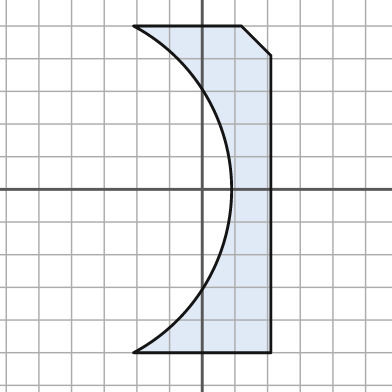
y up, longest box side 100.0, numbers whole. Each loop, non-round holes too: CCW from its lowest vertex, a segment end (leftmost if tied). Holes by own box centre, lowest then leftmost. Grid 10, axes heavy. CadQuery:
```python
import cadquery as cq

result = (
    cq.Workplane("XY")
    .moveTo(-21.0, -50.0)
    .lineTo(21.0, -50.0)
    .lineTo(21.0, 41.0)
    .lineTo(12.0, 50.0)
    .lineTo(-21.0, 50.0)
    .threePointArc((9.0, 0.0), (-21.0, -50.0))
    .close()
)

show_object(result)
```